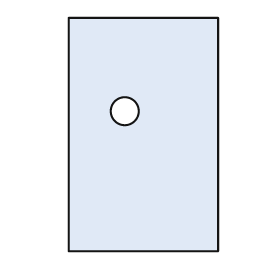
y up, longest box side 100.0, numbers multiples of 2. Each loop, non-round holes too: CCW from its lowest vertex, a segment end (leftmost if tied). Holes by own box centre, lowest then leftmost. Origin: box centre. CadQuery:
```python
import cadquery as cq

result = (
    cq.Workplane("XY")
    .moveTo(-32.0, -50.0)
    .lineTo(32.0, -50.0)
    .lineTo(32.0, 50.0)
    .lineTo(-32.0, 50.0)
    .close()
    .moveTo(-8.0, 10.0)
    .circle(6.0)
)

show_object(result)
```